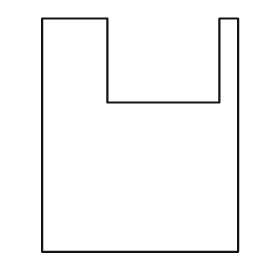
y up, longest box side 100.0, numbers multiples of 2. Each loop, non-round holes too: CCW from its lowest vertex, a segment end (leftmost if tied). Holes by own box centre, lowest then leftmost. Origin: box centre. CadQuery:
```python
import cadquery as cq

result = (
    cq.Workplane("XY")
    .moveTo(-42.0, -50.0)
    .lineTo(42.0, -50.0)
    .lineTo(42.0, 50.0)
    .lineTo(34.0, 50.0)
    .lineTo(34.0, 14.0)
    .lineTo(-14.0, 14.0)
    .lineTo(-14.0, 50.0)
    .lineTo(-42.0, 50.0)
    .close()
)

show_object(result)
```